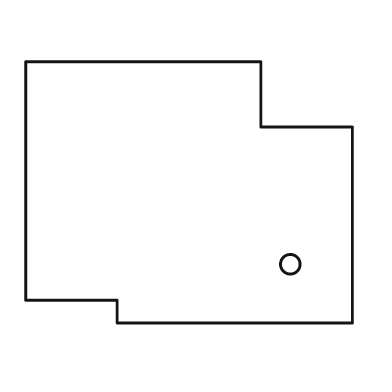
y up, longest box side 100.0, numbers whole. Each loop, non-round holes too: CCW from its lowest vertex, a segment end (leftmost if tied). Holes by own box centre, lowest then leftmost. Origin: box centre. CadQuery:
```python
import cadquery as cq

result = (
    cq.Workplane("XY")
    .moveTo(-22.0, -40.0)
    .lineTo(50.0, -40.0)
    .lineTo(50.0, 20.0)
    .lineTo(22.0, 20.0)
    .lineTo(22.0, 40.0)
    .lineTo(-50.0, 40.0)
    .lineTo(-50.0, -33.0)
    .lineTo(-22.0, -33.0)
    .close()
    .moveTo(31.0, -22.0)
    .circle(3.0)
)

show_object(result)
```